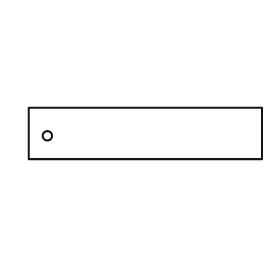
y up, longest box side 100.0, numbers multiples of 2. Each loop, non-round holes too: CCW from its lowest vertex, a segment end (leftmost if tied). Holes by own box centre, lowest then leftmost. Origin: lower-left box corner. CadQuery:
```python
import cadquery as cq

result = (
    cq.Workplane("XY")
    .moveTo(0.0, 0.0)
    .lineTo(100.0, 0.0)
    .lineTo(100.0, 22.0)
    .lineTo(0.0, 22.0)
    .close()
    .moveTo(8.0, 10.0)
    .circle(2.0)
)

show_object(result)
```